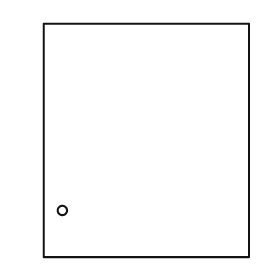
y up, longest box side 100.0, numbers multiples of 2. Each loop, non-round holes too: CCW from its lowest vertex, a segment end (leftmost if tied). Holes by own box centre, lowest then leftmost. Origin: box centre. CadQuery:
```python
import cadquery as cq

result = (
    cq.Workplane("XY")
    .moveTo(-44.0, -50.0)
    .lineTo(44.0, -50.0)
    .lineTo(44.0, 50.0)
    .lineTo(-44.0, 50.0)
    .close()
    .moveTo(-36.0, -30.0)
    .circle(2.0)
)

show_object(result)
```